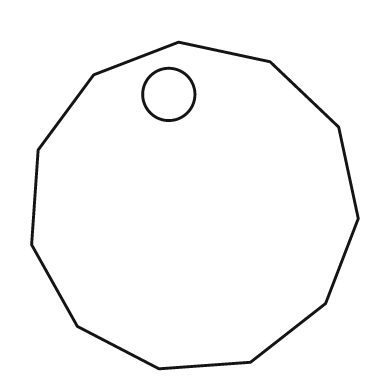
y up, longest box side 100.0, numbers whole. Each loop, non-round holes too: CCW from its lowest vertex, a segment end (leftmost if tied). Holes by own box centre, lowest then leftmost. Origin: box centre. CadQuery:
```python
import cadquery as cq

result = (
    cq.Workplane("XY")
    .moveTo(-11.0, -50.0)
    .lineTo(17.0, -48.0)
    .lineTo(40.0, -30.0)
    .lineTo(50.0, -4.0)
    .lineTo(44.0, 24.0)
    .lineTo(23.0, 44.0)
    .lineTo(-5.0, 50.0)
    .lineTo(-31.0, 40.0)
    .lineTo(-48.0, 17.0)
    .lineTo(-50.0, -12.0)
    .lineTo(-36.0, -37.0)
    .close()
    .moveTo(-8.0, 34.0)
    .circle(8.0)
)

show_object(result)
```